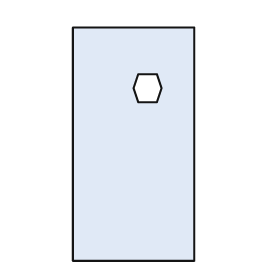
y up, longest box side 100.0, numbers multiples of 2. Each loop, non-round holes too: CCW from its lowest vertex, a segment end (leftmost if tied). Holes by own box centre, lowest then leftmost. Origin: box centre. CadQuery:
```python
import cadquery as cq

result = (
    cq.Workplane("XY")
    .moveTo(-26.0, -50.0)
    .lineTo(26.0, -50.0)
    .lineTo(26.0, 50.0)
    .lineTo(-26.0, 50.0)
    .close()
    .moveTo(2.0, 18.0)
    .lineTo(10.0, 18.0)
    .lineTo(12.0, 24.0)
    .lineTo(10.0, 30.0)
    .lineTo(2.0, 30.0)
    .lineTo(0.0, 24.0)
    .close()
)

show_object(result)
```